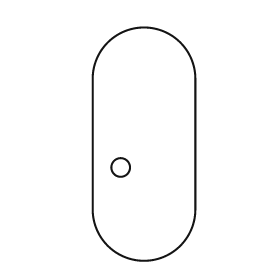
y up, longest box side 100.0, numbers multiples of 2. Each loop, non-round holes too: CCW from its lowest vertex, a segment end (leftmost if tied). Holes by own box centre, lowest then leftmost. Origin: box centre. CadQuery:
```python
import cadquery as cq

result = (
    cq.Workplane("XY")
    .moveTo(-22.0, -28.0)
    .threePointArc((0.0, -50.0), (22.0, -28.0))
    .lineTo(22.0, 28.0)
    .threePointArc((0.0, 50.0), (-22.0, 28.0))
    .close()
    .moveTo(-10.0, -10.0)
    .circle(4.0)
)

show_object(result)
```